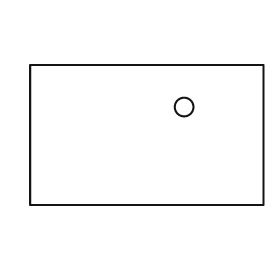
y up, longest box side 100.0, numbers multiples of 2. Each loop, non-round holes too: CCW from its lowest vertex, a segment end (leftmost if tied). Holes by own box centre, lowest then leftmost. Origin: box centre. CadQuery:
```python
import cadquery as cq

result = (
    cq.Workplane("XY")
    .moveTo(-50.0, -30.0)
    .lineTo(50.0, -30.0)
    .lineTo(50.0, 30.0)
    .lineTo(-50.0, 30.0)
    .close()
    .moveTo(16.0, 12.0)
    .circle(4.0)
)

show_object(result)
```